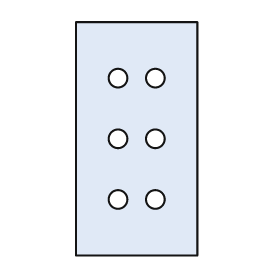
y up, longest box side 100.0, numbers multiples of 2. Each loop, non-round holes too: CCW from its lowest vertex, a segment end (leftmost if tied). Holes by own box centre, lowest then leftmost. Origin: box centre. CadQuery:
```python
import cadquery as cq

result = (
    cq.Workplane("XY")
    .moveTo(-26.0, -50.0)
    .lineTo(26.0, -50.0)
    .lineTo(26.0, 50.0)
    .lineTo(-26.0, 50.0)
    .close()
    .moveTo(-8.0, -26.0)
    .circle(4.0)
    .moveTo(8.0, -26.0)
    .circle(4.0)
    .moveTo(-8.0, 0.0)
    .circle(4.0)
    .moveTo(8.0, 0.0)
    .circle(4.0)
    .moveTo(-8.0, 26.0)
    .circle(4.0)
    .moveTo(8.0, 26.0)
    .circle(4.0)
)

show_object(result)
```